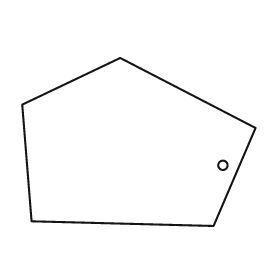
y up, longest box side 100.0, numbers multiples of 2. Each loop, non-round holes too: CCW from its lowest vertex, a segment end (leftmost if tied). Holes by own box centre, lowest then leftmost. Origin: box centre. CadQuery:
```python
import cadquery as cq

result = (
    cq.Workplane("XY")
    .moveTo(32.0, -36.0)
    .lineTo(50.0, 6.0)
    .lineTo(-8.0, 36.0)
    .lineTo(-50.0, 16.0)
    .lineTo(-46.0, -34.0)
    .close()
    .moveTo(36.0, -10.0)
    .circle(2.0)
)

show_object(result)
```